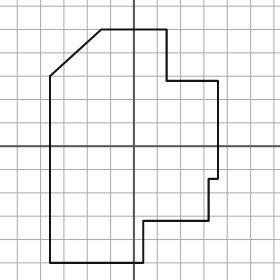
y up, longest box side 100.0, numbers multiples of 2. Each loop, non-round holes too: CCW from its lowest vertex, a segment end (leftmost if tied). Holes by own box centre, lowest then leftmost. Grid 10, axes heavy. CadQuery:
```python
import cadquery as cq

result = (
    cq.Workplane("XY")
    .moveTo(-36.0, -50.0)
    .lineTo(4.0, -50.0)
    .lineTo(4.0, -32.0)
    .lineTo(32.0, -32.0)
    .lineTo(32.0, -14.0)
    .lineTo(36.0, -14.0)
    .lineTo(36.0, 28.0)
    .lineTo(14.0, 28.0)
    .lineTo(14.0, 50.0)
    .lineTo(-14.0, 50.0)
    .lineTo(-36.0, 30.0)
    .close()
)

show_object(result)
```